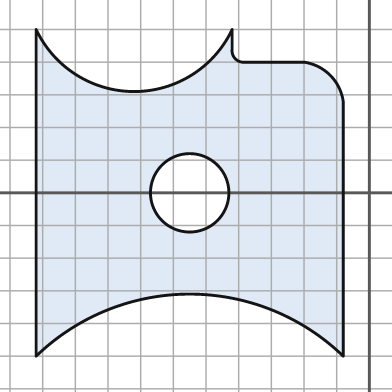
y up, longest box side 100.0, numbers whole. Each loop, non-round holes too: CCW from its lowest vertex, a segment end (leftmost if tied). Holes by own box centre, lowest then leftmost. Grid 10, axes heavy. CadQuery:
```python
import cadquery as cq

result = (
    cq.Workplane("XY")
    .moveTo(-102.0, -50.0)
    .threePointArc((-55.0, -31.0), (-8.0, -50.0))
    .lineTo(-8.0, 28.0)
    .threePointArc((-12.0, 36.0), (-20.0, 40.0))
    .lineTo(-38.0, 40.0)
    .threePointArc((-41.0, 41.0), (-42.0, 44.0))
    .lineTo(-42.0, 50.0)
    .threePointArc((-72.0, 31.0), (-102.0, 50.0))
    .close()
    .moveTo(-55.0, 0.0)
    .circle(12.0)
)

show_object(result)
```